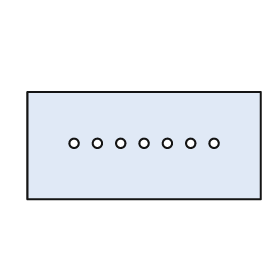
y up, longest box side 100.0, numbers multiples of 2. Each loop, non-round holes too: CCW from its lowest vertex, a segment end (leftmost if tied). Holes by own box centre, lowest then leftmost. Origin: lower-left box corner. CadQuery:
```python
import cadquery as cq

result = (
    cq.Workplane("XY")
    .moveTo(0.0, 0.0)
    .lineTo(100.0, 0.0)
    .lineTo(100.0, 46.0)
    .lineTo(0.0, 46.0)
    .close()
    .moveTo(20.0, 24.0)
    .circle(2.0)
    .moveTo(30.0, 24.0)
    .circle(2.0)
    .moveTo(40.0, 24.0)
    .circle(2.0)
    .moveTo(50.0, 24.0)
    .circle(2.0)
    .moveTo(60.0, 24.0)
    .circle(2.0)
    .moveTo(70.0, 24.0)
    .circle(2.0)
    .moveTo(80.0, 24.0)
    .circle(2.0)
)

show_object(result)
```